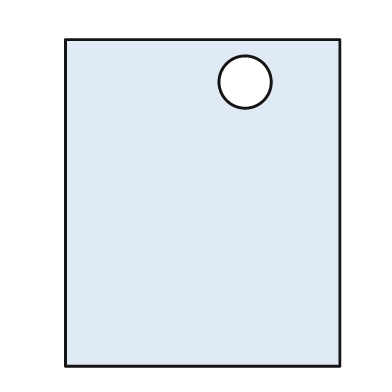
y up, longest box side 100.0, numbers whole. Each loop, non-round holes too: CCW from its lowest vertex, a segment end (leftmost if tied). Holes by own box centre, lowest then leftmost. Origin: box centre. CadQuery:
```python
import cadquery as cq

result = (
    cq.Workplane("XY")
    .moveTo(-42.0, -50.0)
    .lineTo(42.0, -50.0)
    .lineTo(42.0, 50.0)
    .lineTo(-42.0, 50.0)
    .close()
    .moveTo(13.0, 37.0)
    .circle(8.0)
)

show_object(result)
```